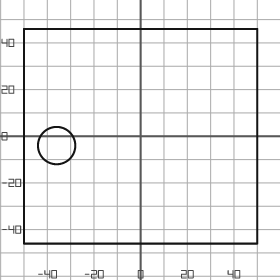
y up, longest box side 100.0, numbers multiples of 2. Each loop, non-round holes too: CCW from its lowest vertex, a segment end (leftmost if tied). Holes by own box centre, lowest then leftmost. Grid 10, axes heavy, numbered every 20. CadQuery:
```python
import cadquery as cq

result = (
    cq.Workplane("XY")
    .moveTo(-50.0, -46.0)
    .lineTo(50.0, -46.0)
    .lineTo(50.0, 46.0)
    .lineTo(-50.0, 46.0)
    .close()
    .moveTo(-36.0, -4.0)
    .circle(8.0)
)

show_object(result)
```